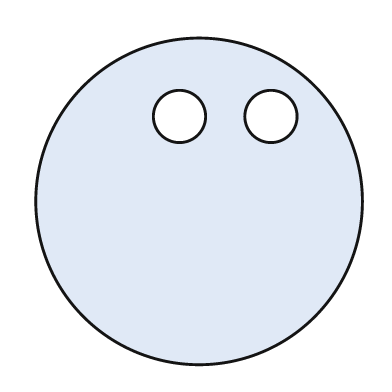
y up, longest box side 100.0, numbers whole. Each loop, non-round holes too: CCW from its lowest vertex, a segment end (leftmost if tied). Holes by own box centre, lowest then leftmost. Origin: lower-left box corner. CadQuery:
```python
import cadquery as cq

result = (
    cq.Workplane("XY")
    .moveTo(50.0, 50.0)
    .circle(50.0)
    .moveTo(44.0, 76.0)
    .circle(8.0)
    .moveTo(72.0, 76.0)
    .circle(8.0)
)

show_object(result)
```